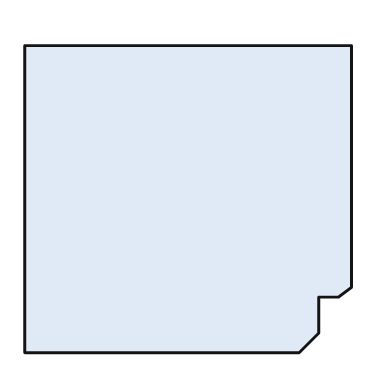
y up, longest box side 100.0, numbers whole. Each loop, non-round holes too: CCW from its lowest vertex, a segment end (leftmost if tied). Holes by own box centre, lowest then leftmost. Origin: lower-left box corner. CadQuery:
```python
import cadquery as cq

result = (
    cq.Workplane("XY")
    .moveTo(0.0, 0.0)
    .lineTo(84.0, 0.0)
    .lineTo(90.0, 6.0)
    .lineTo(90.0, 17.0)
    .lineTo(96.0, 17.0)
    .lineTo(100.0, 20.0)
    .lineTo(100.0, 94.0)
    .lineTo(0.0, 94.0)
    .close()
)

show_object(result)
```